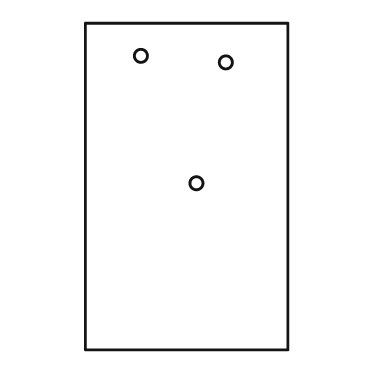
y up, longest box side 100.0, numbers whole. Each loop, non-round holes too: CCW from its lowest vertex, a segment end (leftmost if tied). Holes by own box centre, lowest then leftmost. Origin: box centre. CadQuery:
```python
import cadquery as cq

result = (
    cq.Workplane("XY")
    .moveTo(-31.0, -50.0)
    .lineTo(31.0, -50.0)
    .lineTo(31.0, 50.0)
    .lineTo(-31.0, 50.0)
    .close()
    .moveTo(3.0, 1.0)
    .circle(2.0)
    .moveTo(12.0, 38.0)
    .circle(2.0)
    .moveTo(-14.0, 40.0)
    .circle(2.0)
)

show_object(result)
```